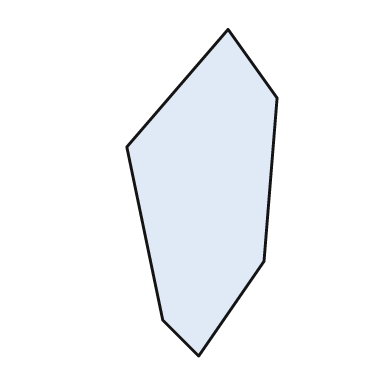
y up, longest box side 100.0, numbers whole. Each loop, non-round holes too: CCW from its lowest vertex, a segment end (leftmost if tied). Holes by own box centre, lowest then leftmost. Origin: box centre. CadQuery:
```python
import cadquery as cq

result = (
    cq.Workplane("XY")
    .moveTo(-1.0, -50.0)
    .lineTo(19.0, -21.0)
    .lineTo(23.0, 29.0)
    .lineTo(8.0, 50.0)
    .lineTo(-23.0, 14.0)
    .lineTo(-12.0, -39.0)
    .close()
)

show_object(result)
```